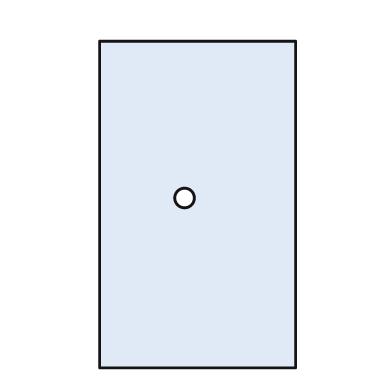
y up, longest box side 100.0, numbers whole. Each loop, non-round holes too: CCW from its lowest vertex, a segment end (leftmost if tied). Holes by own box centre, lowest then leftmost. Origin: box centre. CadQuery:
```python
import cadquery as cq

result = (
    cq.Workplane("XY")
    .moveTo(-30.0, -50.0)
    .lineTo(30.0, -50.0)
    .lineTo(30.0, 50.0)
    .lineTo(-30.0, 50.0)
    .close()
    .moveTo(-4.0, 2.0)
    .circle(3.0)
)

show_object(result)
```